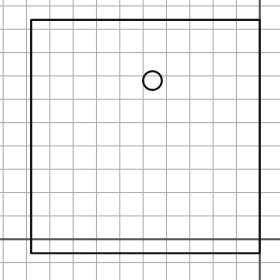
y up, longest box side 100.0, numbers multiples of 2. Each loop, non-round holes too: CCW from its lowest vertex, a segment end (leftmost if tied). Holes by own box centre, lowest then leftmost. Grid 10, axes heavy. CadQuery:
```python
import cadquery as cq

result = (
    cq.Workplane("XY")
    .moveTo(-98.0, -6.0)
    .lineTo(0.0, -6.0)
    .lineTo(0.0, 94.0)
    .lineTo(-98.0, 94.0)
    .close()
    .moveTo(-46.0, 68.0)
    .circle(4.0)
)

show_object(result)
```